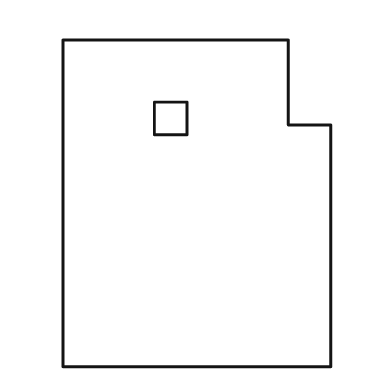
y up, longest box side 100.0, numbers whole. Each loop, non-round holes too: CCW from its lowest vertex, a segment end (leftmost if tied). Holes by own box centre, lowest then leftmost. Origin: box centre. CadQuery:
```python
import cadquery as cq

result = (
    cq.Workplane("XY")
    .moveTo(-41.0, -50.0)
    .lineTo(41.0, -50.0)
    .lineTo(41.0, 24.0)
    .lineTo(28.0, 24.0)
    .lineTo(28.0, 50.0)
    .lineTo(-41.0, 50.0)
    .close()
    .moveTo(-13.0, 21.0)
    .lineTo(-3.0, 21.0)
    .lineTo(-3.0, 31.0)
    .lineTo(-13.0, 31.0)
    .close()
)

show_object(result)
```